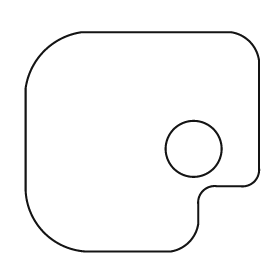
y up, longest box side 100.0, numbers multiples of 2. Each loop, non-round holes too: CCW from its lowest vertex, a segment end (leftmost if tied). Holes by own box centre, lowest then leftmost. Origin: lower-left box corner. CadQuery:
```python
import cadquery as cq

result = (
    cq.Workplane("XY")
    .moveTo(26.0, 0.0)
    .lineTo(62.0, 0.0)
    .threePointArc((70.0, 4.0), (74.0, 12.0))
    .lineTo(74.0, 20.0)
    .threePointArc((76.0, 26.0), (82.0, 28.0))
    .lineTo(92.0, 28.0)
    .threePointArc((98.0, 30.0), (100.0, 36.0))
    .lineTo(100.0, 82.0)
    .threePointArc((96.0, 90.0), (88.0, 94.0))
    .lineTo(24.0, 94.0)
    .threePointArc((8.0, 86.0), (0.0, 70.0))
    .lineTo(0.0, 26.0)
    .threePointArc((8.0, 8.0), (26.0, 0.0))
    .close()
    .moveTo(72.0, 44.0)
    .circle(12.0)
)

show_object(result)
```